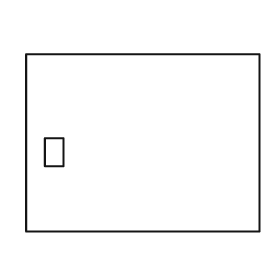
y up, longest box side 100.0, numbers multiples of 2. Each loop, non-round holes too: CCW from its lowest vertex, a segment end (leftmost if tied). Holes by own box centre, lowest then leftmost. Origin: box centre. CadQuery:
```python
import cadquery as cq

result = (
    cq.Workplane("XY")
    .moveTo(-50.0, -38.0)
    .lineTo(50.0, -38.0)
    .lineTo(50.0, 38.0)
    .lineTo(-50.0, 38.0)
    .close()
    .moveTo(-42.0, -10.0)
    .lineTo(-34.0, -10.0)
    .lineTo(-34.0, 2.0)
    .lineTo(-42.0, 2.0)
    .close()
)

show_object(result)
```